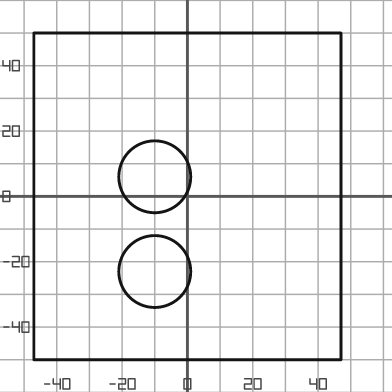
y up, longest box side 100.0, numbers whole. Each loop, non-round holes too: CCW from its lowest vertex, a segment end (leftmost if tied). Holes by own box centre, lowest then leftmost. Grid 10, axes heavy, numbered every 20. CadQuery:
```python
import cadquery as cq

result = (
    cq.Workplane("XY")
    .moveTo(-47.0, -50.0)
    .lineTo(47.0, -50.0)
    .lineTo(47.0, 50.0)
    .lineTo(-47.0, 50.0)
    .close()
    .moveTo(-10.0, -23.0)
    .circle(11.0)
    .moveTo(-10.0, 6.0)
    .circle(11.0)
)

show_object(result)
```